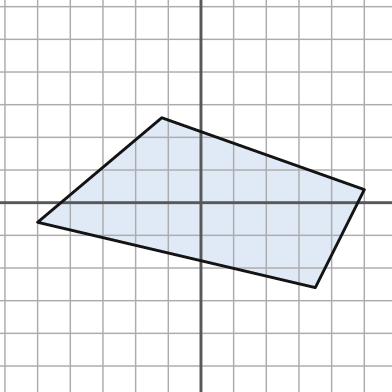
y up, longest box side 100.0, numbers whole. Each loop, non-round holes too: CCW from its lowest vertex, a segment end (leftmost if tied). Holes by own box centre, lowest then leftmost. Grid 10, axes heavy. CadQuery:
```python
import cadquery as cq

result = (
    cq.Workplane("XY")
    .moveTo(35.0, -26.0)
    .lineTo(50.0, 4.0)
    .lineTo(-12.0, 26.0)
    .lineTo(-50.0, -6.0)
    .close()
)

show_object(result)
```